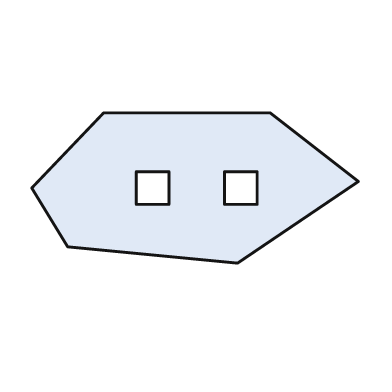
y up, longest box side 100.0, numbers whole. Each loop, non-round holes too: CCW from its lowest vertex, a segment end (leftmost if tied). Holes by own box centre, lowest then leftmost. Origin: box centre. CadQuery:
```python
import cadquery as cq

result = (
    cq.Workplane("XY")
    .moveTo(13.0, -23.0)
    .lineTo(50.0, 2.0)
    .lineTo(23.0, 23.0)
    .lineTo(-28.0, 23.0)
    .lineTo(-50.0, 0.0)
    .lineTo(-39.0, -18.0)
    .close()
    .moveTo(-18.0, -5.0)
    .lineTo(-8.0, -5.0)
    .lineTo(-8.0, 5.0)
    .lineTo(-18.0, 5.0)
    .close()
    .moveTo(9.0, -5.0)
    .lineTo(19.0, -5.0)
    .lineTo(19.0, 5.0)
    .lineTo(9.0, 5.0)
    .close()
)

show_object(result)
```